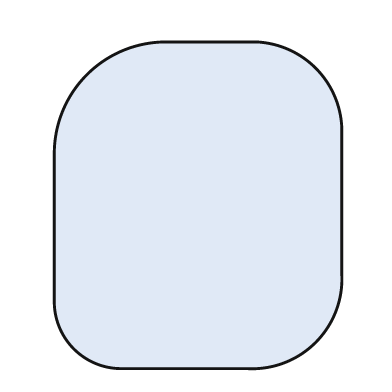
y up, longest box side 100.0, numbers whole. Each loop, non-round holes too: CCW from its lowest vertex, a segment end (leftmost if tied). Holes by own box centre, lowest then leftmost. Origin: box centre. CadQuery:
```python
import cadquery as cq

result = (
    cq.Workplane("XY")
    .moveTo(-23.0, -50.0)
    .lineTo(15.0, -50.0)
    .threePointArc((36.0, -42.0), (44.0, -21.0))
    .lineTo(44.0, 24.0)
    .threePointArc((36.0, 42.0), (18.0, 50.0))
    .lineTo(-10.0, 50.0)
    .threePointArc((-34.0, 40.0), (-44.0, 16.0))
    .lineTo(-44.0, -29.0)
    .threePointArc((-38.0, -44.0), (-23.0, -50.0))
    .close()
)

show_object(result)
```